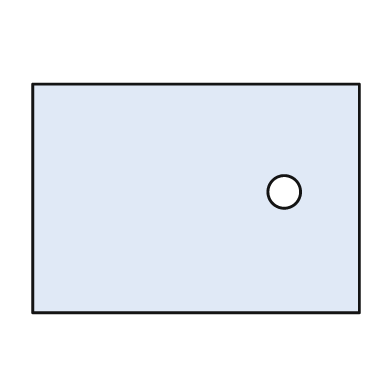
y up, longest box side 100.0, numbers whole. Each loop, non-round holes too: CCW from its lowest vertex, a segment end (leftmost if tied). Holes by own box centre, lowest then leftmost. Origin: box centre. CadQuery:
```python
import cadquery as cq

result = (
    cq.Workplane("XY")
    .moveTo(-50.0, -35.0)
    .lineTo(50.0, -35.0)
    .lineTo(50.0, 35.0)
    .lineTo(-50.0, 35.0)
    .close()
    .moveTo(27.0, 2.0)
    .circle(5.0)
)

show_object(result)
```